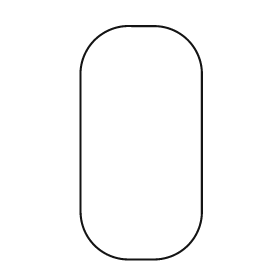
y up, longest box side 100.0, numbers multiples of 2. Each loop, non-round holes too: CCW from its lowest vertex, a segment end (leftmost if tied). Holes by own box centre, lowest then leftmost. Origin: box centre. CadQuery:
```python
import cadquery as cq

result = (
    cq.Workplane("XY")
    .moveTo(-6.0, -50.0)
    .lineTo(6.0, -50.0)
    .threePointArc((20.0, -44.0), (26.0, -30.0))
    .lineTo(26.0, 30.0)
    .threePointArc((20.0, 44.0), (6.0, 50.0))
    .lineTo(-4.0, 50.0)
    .threePointArc((-20.0, 44.0), (-26.0, 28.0))
    .lineTo(-26.0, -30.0)
    .threePointArc((-20.0, -44.0), (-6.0, -50.0))
    .close()
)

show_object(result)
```